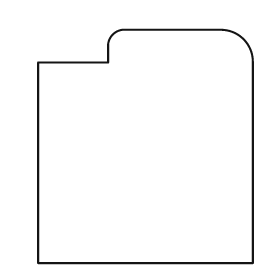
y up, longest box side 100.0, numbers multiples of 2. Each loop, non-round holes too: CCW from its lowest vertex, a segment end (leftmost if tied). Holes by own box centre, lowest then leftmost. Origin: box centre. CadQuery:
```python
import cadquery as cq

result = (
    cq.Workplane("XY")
    .moveTo(-46.0, -50.0)
    .lineTo(46.0, -50.0)
    .lineTo(46.0, 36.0)
    .threePointArc((42.0, 46.0), (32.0, 50.0))
    .lineTo(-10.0, 50.0)
    .threePointArc((-14.0, 48.0), (-16.0, 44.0))
    .lineTo(-16.0, 36.0)
    .lineTo(-46.0, 36.0)
    .close()
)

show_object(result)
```